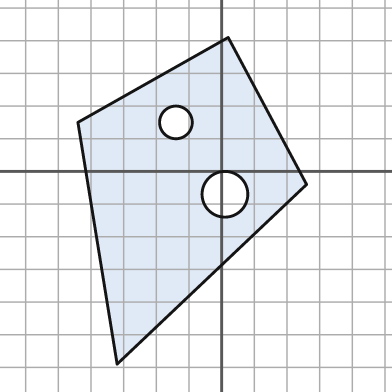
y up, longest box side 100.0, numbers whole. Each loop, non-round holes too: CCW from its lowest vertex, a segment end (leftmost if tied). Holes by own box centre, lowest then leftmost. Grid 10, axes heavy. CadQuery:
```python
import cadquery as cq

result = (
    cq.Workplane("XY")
    .moveTo(-32.0, -59.0)
    .lineTo(26.0, -4.0)
    .lineTo(2.0, 41.0)
    .lineTo(-44.0, 15.0)
    .close()
    .moveTo(1.0, -7.0)
    .circle(7.0)
    .moveTo(-14.0, 15.0)
    .circle(5.0)
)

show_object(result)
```